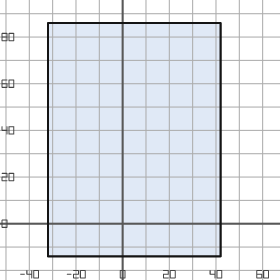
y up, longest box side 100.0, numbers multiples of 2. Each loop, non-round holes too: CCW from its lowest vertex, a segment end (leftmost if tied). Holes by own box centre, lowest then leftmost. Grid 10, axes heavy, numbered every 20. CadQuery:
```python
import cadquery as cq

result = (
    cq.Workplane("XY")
    .moveTo(-32.0, -14.0)
    .lineTo(42.0, -14.0)
    .lineTo(42.0, 86.0)
    .lineTo(-32.0, 86.0)
    .close()
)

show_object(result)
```